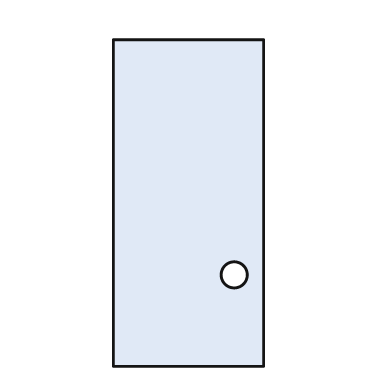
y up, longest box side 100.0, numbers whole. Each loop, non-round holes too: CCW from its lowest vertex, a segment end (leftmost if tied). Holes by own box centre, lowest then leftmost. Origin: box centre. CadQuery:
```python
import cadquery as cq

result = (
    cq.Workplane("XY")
    .moveTo(-23.0, -50.0)
    .lineTo(23.0, -50.0)
    .lineTo(23.0, 50.0)
    .lineTo(-23.0, 50.0)
    .close()
    .moveTo(14.0, -22.0)
    .circle(4.0)
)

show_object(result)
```